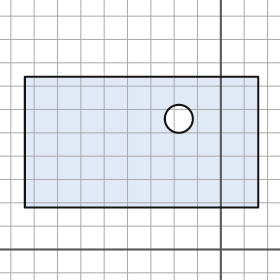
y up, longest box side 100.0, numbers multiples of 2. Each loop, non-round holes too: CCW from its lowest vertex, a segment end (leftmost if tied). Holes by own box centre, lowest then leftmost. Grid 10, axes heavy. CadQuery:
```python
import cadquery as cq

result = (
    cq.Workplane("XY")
    .moveTo(-84.0, 18.0)
    .lineTo(16.0, 18.0)
    .lineTo(16.0, 74.0)
    .lineTo(-84.0, 74.0)
    .close()
    .moveTo(-18.0, 56.0)
    .circle(6.0)
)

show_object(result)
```